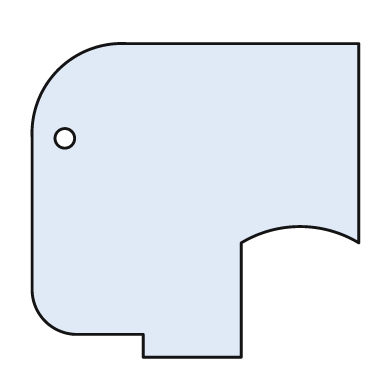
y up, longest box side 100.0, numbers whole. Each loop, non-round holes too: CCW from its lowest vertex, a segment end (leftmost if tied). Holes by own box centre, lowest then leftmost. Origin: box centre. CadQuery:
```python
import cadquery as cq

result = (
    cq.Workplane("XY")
    .moveTo(-16.0, -48.0)
    .lineTo(14.0, -48.0)
    .lineTo(14.0, -13.0)
    .threePointArc((32.0, -8.0), (50.0, -13.0))
    .lineTo(50.0, 48.0)
    .lineTo(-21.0, 48.0)
    .threePointArc((-42.0, 40.0), (-50.0, 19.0))
    .lineTo(-50.0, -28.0)
    .threePointArc((-46.0, -37.0), (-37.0, -41.0))
    .lineTo(-16.0, -41.0)
    .close()
    .moveTo(-40.0, 19.0)
    .circle(3.0)
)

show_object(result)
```